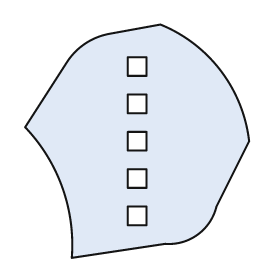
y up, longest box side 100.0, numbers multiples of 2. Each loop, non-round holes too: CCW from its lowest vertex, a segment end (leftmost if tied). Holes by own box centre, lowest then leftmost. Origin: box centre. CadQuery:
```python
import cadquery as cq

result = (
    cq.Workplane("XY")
    .moveTo(-28.0, -50.0)
    .lineTo(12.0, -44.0)
    .threePointArc((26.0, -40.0), (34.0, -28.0))
    .lineTo(48.0, 0.0)
    .threePointArc((36.0, 30.0), (10.0, 50.0))
    .lineTo(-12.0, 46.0)
    .threePointArc((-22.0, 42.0), (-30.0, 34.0))
    .lineTo(-48.0, 6.0)
    .threePointArc((-32.0, -20.0), (-28.0, -50.0))
    .close()
    .moveTo(-4.0, -36.0)
    .lineTo(4.0, -36.0)
    .lineTo(4.0, -28.0)
    .lineTo(-4.0, -28.0)
    .close()
    .moveTo(-4.0, -20.0)
    .lineTo(4.0, -20.0)
    .lineTo(4.0, -12.0)
    .lineTo(-4.0, -12.0)
    .close()
    .moveTo(-4.0, -4.0)
    .lineTo(4.0, -4.0)
    .lineTo(4.0, 4.0)
    .lineTo(-4.0, 4.0)
    .close()
    .moveTo(-4.0, 12.0)
    .lineTo(4.0, 12.0)
    .lineTo(4.0, 20.0)
    .lineTo(-4.0, 20.0)
    .close()
    .moveTo(-4.0, 28.0)
    .lineTo(4.0, 28.0)
    .lineTo(4.0, 36.0)
    .lineTo(-4.0, 36.0)
    .close()
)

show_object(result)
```